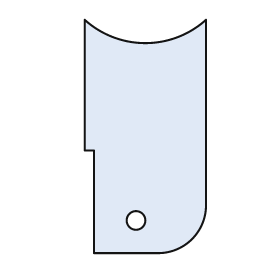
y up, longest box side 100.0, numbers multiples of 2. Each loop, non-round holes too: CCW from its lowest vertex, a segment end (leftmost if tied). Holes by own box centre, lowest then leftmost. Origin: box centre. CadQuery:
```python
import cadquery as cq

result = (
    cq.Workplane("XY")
    .moveTo(-22.0, -50.0)
    .lineTo(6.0, -50.0)
    .threePointArc((20.0, -44.0), (26.0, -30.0))
    .lineTo(26.0, 50.0)
    .threePointArc((0.0, 40.0), (-26.0, 50.0))
    .lineTo(-26.0, -6.0)
    .lineTo(-22.0, -6.0)
    .close()
    .moveTo(-4.0, -36.0)
    .circle(4.0)
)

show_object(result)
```